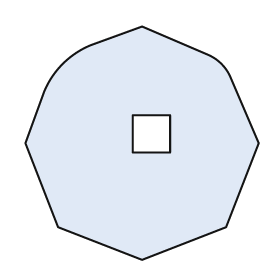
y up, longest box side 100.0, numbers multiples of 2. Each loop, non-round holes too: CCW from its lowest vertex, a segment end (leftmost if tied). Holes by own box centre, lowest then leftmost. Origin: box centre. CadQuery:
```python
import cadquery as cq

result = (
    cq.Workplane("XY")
    .moveTo(0.0, -50.0)
    .lineTo(36.0, -36.0)
    .lineTo(50.0, 0.0)
    .lineTo(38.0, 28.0)
    .threePointArc((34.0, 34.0), (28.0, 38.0))
    .lineTo(0.0, 50.0)
    .lineTo(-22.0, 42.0)
    .threePointArc((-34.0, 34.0), (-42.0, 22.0))
    .lineTo(-50.0, 0.0)
    .lineTo(-36.0, -36.0)
    .close()
    .moveTo(-4.0, -4.0)
    .lineTo(12.0, -4.0)
    .lineTo(12.0, 12.0)
    .lineTo(-4.0, 12.0)
    .close()
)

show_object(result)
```